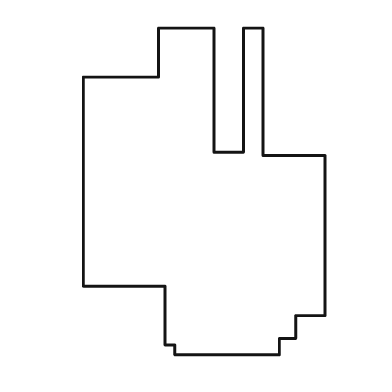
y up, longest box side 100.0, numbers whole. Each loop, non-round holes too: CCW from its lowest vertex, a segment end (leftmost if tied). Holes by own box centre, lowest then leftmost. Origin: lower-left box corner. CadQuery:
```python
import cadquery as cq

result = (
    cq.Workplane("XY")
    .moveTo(28.0, 0.0)
    .lineTo(60.0, 0.0)
    .lineTo(60.0, 5.0)
    .lineTo(65.0, 5.0)
    .lineTo(65.0, 12.0)
    .lineTo(74.0, 12.0)
    .lineTo(74.0, 61.0)
    .lineTo(55.0, 61.0)
    .lineTo(55.0, 100.0)
    .lineTo(49.0, 100.0)
    .lineTo(49.0, 62.0)
    .lineTo(40.0, 62.0)
    .lineTo(40.0, 100.0)
    .lineTo(23.0, 100.0)
    .lineTo(23.0, 85.0)
    .lineTo(0.0, 85.0)
    .lineTo(0.0, 21.0)
    .lineTo(25.0, 21.0)
    .lineTo(25.0, 3.0)
    .lineTo(28.0, 3.0)
    .close()
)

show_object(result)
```